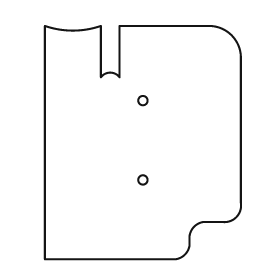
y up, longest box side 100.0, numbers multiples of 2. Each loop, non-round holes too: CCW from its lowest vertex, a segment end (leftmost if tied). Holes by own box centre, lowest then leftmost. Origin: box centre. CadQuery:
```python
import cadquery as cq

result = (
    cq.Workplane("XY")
    .moveTo(-42.0, -50.0)
    .lineTo(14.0, -50.0)
    .threePointArc((18.0, -48.0), (20.0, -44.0))
    .lineTo(20.0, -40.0)
    .threePointArc((22.0, -36.0), (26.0, -34.0))
    .lineTo(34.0, -34.0)
    .threePointArc((40.0, -32.0), (42.0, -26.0))
    .lineTo(42.0, 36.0)
    .threePointArc((38.0, 46.0), (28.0, 50.0))
    .lineTo(-10.0, 50.0)
    .lineTo(-10.0, 28.0)
    .threePointArc((-14.0, 30.0), (-18.0, 28.0))
    .lineTo(-18.0, 50.0)
    .threePointArc((-30.0, 48.0), (-42.0, 50.0))
    .close()
    .moveTo(0.0, -16.0)
    .circle(2.0)
    .moveTo(0.0, 18.0)
    .circle(2.0)
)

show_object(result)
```